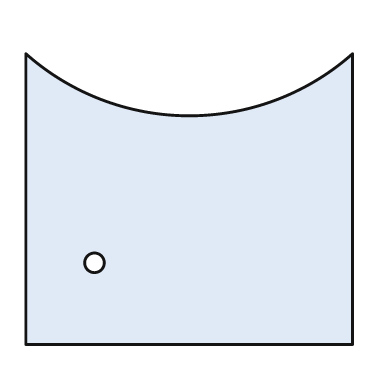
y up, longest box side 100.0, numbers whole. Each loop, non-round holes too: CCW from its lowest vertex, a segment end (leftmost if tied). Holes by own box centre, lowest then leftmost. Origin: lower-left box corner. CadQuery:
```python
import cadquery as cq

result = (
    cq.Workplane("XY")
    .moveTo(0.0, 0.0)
    .lineTo(100.0, 0.0)
    .lineTo(100.0, 89.0)
    .threePointArc((50.0, 70.0), (0.0, 89.0))
    .close()
    .moveTo(21.0, 25.0)
    .circle(3.0)
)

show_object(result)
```